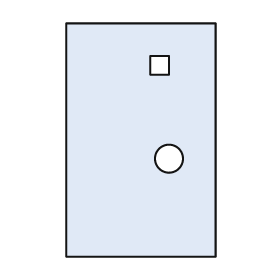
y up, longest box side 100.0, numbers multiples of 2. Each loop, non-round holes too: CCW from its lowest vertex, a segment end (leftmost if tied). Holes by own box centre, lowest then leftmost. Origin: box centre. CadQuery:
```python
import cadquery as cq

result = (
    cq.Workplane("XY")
    .moveTo(-32.0, -50.0)
    .lineTo(32.0, -50.0)
    .lineTo(32.0, 50.0)
    .lineTo(-32.0, 50.0)
    .close()
    .moveTo(12.0, -8.0)
    .circle(6.0)
    .moveTo(4.0, 28.0)
    .lineTo(12.0, 28.0)
    .lineTo(12.0, 36.0)
    .lineTo(4.0, 36.0)
    .close()
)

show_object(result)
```